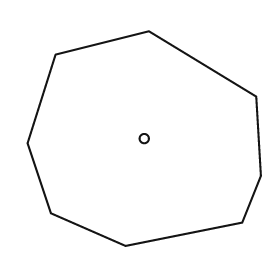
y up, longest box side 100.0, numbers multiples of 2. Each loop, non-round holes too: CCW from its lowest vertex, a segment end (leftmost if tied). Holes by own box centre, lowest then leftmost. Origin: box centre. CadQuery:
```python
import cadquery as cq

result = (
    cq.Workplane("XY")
    .moveTo(-8.0, -46.0)
    .lineTo(42.0, -36.0)
    .lineTo(50.0, -16.0)
    .lineTo(48.0, 18.0)
    .lineTo(2.0, 46.0)
    .lineTo(-38.0, 36.0)
    .lineTo(-50.0, -2.0)
    .lineTo(-40.0, -32.0)
    .close()
    .moveTo(0.0, 0.0)
    .circle(2.0)
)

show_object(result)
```